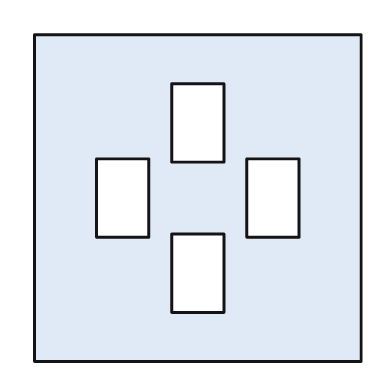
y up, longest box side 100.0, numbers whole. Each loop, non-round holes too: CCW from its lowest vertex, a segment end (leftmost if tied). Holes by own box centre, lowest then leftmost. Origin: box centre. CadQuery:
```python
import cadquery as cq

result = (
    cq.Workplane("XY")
    .moveTo(-50.0, -50.0)
    .lineTo(50.0, -50.0)
    .lineTo(50.0, 50.0)
    .lineTo(-50.0, 50.0)
    .close()
    .moveTo(-8.0, -35.0)
    .lineTo(8.0, -35.0)
    .lineTo(8.0, -11.0)
    .lineTo(-8.0, -11.0)
    .close()
    .moveTo(-31.0, -12.0)
    .lineTo(-15.0, -12.0)
    .lineTo(-15.0, 12.0)
    .lineTo(-31.0, 12.0)
    .close()
    .moveTo(15.0, -12.0)
    .lineTo(31.0, -12.0)
    .lineTo(31.0, 12.0)
    .lineTo(15.0, 12.0)
    .close()
    .moveTo(-8.0, 11.0)
    .lineTo(8.0, 11.0)
    .lineTo(8.0, 35.0)
    .lineTo(-8.0, 35.0)
    .close()
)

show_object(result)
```